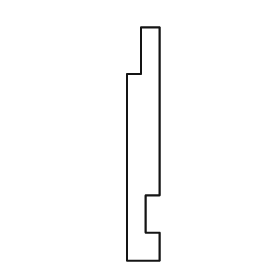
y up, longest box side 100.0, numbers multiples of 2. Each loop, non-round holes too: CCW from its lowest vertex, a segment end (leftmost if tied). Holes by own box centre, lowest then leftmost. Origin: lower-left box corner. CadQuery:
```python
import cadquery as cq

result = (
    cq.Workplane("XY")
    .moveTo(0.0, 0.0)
    .lineTo(14.0, 0.0)
    .lineTo(14.0, 12.0)
    .lineTo(8.0, 12.0)
    .lineTo(8.0, 28.0)
    .lineTo(14.0, 28.0)
    .lineTo(14.0, 100.0)
    .lineTo(6.0, 100.0)
    .lineTo(6.0, 80.0)
    .lineTo(0.0, 80.0)
    .close()
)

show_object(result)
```